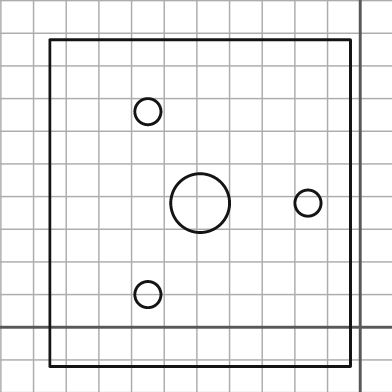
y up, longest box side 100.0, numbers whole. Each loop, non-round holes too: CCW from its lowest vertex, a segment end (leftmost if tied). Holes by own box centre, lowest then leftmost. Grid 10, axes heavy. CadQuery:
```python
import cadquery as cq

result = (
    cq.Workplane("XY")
    .moveTo(-95.0, -12.0)
    .lineTo(-3.0, -12.0)
    .lineTo(-3.0, 88.0)
    .lineTo(-95.0, 88.0)
    .close()
    .moveTo(-65.0, 10.0)
    .circle(4.0)
    .moveTo(-49.0, 38.0)
    .circle(9.0)
    .moveTo(-16.0, 38.0)
    .circle(4.0)
    .moveTo(-65.0, 66.0)
    .circle(4.0)
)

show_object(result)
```